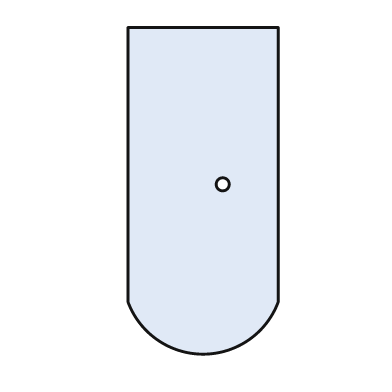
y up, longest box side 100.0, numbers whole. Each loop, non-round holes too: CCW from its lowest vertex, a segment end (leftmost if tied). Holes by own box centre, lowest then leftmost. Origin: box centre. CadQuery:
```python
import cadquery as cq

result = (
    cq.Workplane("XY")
    .moveTo(-23.0, -34.0)
    .threePointArc((0.0, -50.0), (23.0, -34.0))
    .lineTo(23.0, 50.0)
    .lineTo(-23.0, 50.0)
    .close()
    .moveTo(6.0, 2.0)
    .circle(2.0)
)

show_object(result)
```